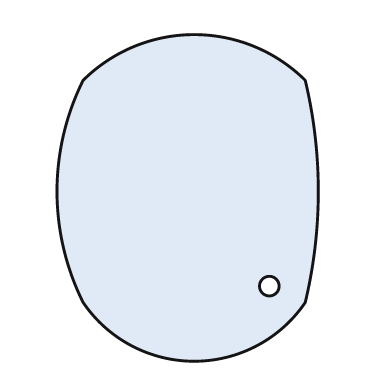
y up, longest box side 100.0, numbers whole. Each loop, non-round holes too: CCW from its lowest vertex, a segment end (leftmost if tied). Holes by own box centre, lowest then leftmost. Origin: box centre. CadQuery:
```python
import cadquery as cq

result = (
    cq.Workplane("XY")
    .moveTo(-32.0, -32.0)
    .threePointArc((2.0, -50.0), (36.0, -32.0))
    .threePointArc((40.0, 2.0), (36.0, 36.0))
    .threePointArc((2.0, 50.0), (-32.0, 36.0))
    .threePointArc((-40.0, 2.0), (-32.0, -32.0))
    .close()
    .moveTo(25.0, -27.0)
    .circle(3.0)
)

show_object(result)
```